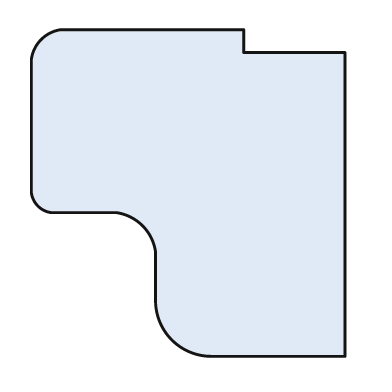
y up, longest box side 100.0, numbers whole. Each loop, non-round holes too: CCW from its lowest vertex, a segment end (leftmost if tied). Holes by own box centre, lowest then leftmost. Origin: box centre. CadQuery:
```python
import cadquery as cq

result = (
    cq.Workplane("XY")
    .moveTo(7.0, -50.0)
    .lineTo(48.0, -50.0)
    .lineTo(48.0, 43.0)
    .lineTo(17.0, 43.0)
    .lineTo(17.0, 50.0)
    .lineTo(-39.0, 50.0)
    .threePointArc((-45.0, 47.0), (-48.0, 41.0))
    .lineTo(-48.0, 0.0)
    .threePointArc((-46.0, -4.0), (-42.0, -6.0))
    .lineTo(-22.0, -6.0)
    .threePointArc((-14.0, -10.0), (-10.0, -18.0))
    .lineTo(-10.0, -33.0)
    .threePointArc((-5.0, -45.0), (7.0, -50.0))
    .close()
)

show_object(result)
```